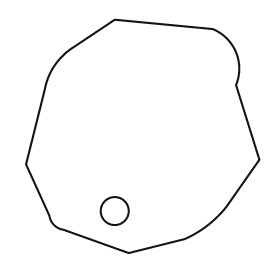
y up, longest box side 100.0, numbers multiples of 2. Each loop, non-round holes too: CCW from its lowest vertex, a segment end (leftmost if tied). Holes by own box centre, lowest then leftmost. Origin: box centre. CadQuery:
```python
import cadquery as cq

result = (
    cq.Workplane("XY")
    .moveTo(-6.0, -50.0)
    .lineTo(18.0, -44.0)
    .threePointArc((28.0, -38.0), (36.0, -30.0))
    .lineTo(50.0, -10.0)
    .lineTo(40.0, 22.0)
    .threePointArc((40.0, 36.0), (30.0, 46.0))
    .lineTo(-12.0, 50.0)
    .lineTo(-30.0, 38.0)
    .threePointArc((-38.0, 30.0), (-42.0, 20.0))
    .lineTo(-50.0, -12.0)
    .lineTo(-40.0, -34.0)
    .threePointArc((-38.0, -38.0), (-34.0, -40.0))
    .close()
    .moveTo(-12.0, -32.0)
    .circle(6.0)
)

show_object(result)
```